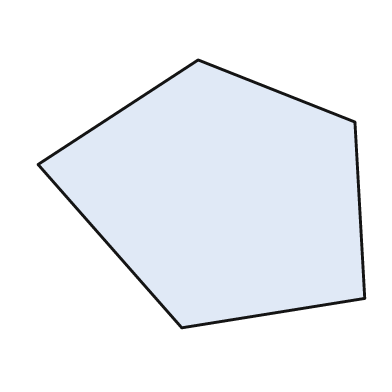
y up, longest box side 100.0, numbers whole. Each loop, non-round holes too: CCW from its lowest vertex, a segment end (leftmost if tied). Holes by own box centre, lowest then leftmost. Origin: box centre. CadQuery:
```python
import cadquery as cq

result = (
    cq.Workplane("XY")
    .moveTo(-6.0, -41.0)
    .lineTo(50.0, -32.0)
    .lineTo(47.0, 22.0)
    .lineTo(-1.0, 41.0)
    .lineTo(-50.0, 9.0)
    .close()
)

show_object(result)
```